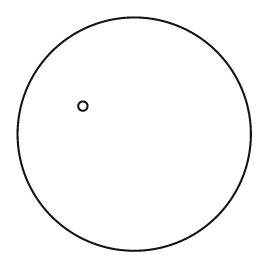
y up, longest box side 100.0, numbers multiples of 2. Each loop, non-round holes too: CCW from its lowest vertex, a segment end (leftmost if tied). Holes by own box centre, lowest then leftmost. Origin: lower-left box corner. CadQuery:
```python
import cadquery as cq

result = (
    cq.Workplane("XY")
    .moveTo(50.0, 50.0)
    .circle(50.0)
    .moveTo(28.0, 62.0)
    .circle(2.0)
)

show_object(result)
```